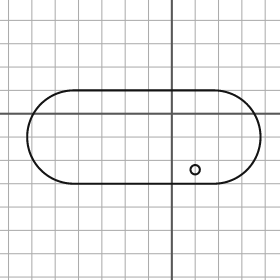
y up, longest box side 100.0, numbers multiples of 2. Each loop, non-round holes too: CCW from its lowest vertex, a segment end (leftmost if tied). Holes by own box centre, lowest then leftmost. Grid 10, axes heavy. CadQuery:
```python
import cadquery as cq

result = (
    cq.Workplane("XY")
    .moveTo(-42.0, -30.0)
    .lineTo(18.0, -30.0)
    .threePointArc((38.0, -10.0), (18.0, 10.0))
    .lineTo(-42.0, 10.0)
    .threePointArc((-62.0, -10.0), (-42.0, -30.0))
    .close()
    .moveTo(10.0, -24.0)
    .circle(2.0)
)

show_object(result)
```